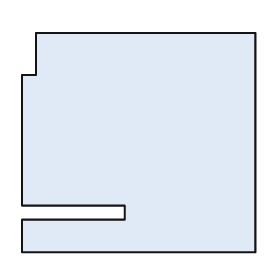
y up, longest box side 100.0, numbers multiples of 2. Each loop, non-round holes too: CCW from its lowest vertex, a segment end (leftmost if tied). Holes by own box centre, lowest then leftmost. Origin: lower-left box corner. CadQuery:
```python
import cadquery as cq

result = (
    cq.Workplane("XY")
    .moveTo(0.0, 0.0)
    .lineTo(100.0, 0.0)
    .lineTo(100.0, 94.0)
    .lineTo(6.0, 94.0)
    .lineTo(6.0, 76.0)
    .lineTo(0.0, 76.0)
    .lineTo(0.0, 20.0)
    .lineTo(44.0, 20.0)
    .lineTo(44.0, 14.0)
    .lineTo(0.0, 14.0)
    .close()
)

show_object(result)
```